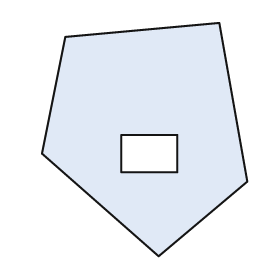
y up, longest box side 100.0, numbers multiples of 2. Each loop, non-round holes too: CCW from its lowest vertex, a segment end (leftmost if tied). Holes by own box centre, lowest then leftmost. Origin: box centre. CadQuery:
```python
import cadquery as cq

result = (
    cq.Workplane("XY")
    .moveTo(6.0, -50.0)
    .lineTo(44.0, -18.0)
    .lineTo(32.0, 50.0)
    .lineTo(-34.0, 44.0)
    .lineTo(-44.0, -6.0)
    .close()
    .moveTo(-10.0, -14.0)
    .lineTo(14.0, -14.0)
    .lineTo(14.0, 2.0)
    .lineTo(-10.0, 2.0)
    .close()
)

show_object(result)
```